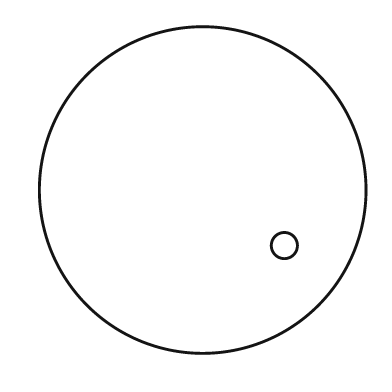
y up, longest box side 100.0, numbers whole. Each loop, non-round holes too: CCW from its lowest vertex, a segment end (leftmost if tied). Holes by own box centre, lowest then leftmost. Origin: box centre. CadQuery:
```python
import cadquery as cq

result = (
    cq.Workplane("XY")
    .moveTo(0.0, 0.0)
    .circle(50.0)
    .moveTo(25.0, -17.0)
    .circle(4.0)
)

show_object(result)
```